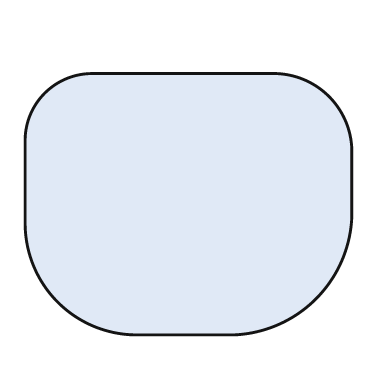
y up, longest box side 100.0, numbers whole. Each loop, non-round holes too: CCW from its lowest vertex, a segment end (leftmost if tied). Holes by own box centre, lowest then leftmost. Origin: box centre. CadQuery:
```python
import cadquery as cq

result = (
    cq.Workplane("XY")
    .moveTo(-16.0, -40.0)
    .lineTo(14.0, -40.0)
    .threePointArc((39.0, -29.0), (50.0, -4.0))
    .lineTo(50.0, 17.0)
    .threePointArc((43.0, 33.0), (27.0, 40.0))
    .lineTo(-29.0, 40.0)
    .threePointArc((-44.0, 34.0), (-50.0, 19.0))
    .lineTo(-50.0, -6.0)
    .threePointArc((-40.0, -30.0), (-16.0, -40.0))
    .close()
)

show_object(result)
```